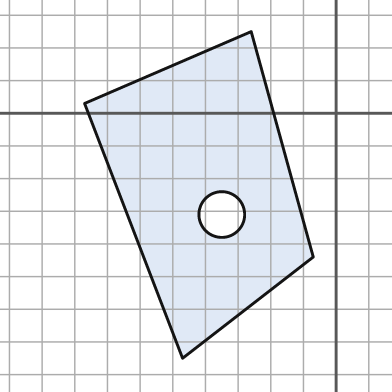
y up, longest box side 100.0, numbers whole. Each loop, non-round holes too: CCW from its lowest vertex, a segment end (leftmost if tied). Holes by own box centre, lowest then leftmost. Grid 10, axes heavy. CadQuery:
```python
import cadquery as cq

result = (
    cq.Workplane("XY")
    .moveTo(-47.0, -75.0)
    .lineTo(-7.0, -44.0)
    .lineTo(-26.0, 25.0)
    .lineTo(-77.0, 3.0)
    .close()
    .moveTo(-35.0, -31.0)
    .circle(7.0)
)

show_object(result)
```